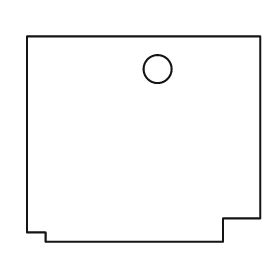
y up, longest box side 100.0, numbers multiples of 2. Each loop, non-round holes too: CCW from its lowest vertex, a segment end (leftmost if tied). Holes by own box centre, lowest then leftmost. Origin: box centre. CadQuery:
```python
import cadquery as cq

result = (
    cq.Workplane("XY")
    .moveTo(-42.0, -44.0)
    .lineTo(34.0, -44.0)
    .lineTo(34.0, -34.0)
    .lineTo(50.0, -34.0)
    .lineTo(50.0, 44.0)
    .lineTo(-50.0, 44.0)
    .lineTo(-50.0, -40.0)
    .lineTo(-42.0, -40.0)
    .close()
    .moveTo(6.0, 30.0)
    .circle(6.0)
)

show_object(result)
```